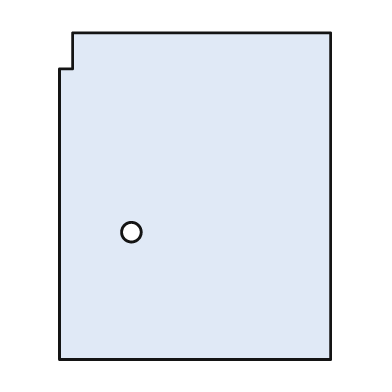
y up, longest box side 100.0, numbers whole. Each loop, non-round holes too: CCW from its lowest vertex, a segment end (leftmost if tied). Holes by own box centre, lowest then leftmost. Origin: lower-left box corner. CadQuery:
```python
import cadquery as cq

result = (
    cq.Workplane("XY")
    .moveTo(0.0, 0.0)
    .lineTo(83.0, 0.0)
    .lineTo(83.0, 100.0)
    .lineTo(4.0, 100.0)
    .lineTo(4.0, 89.0)
    .lineTo(0.0, 89.0)
    .close()
    .moveTo(22.0, 39.0)
    .circle(3.0)
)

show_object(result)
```